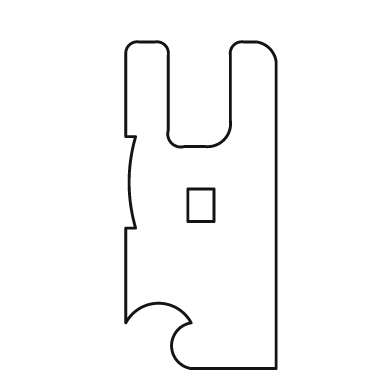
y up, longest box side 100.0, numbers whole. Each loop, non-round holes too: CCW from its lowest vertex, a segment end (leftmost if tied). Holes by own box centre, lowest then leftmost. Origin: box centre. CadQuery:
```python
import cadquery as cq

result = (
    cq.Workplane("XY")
    .moveTo(-3.0, -50.0)
    .lineTo(23.0, -50.0)
    .lineTo(23.0, 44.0)
    .threePointArc((21.0, 48.0), (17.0, 50.0))
    .lineTo(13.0, 50.0)
    .threePointArc((10.0, 49.0), (9.0, 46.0))
    .lineTo(9.0, 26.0)
    .threePointArc((7.0, 20.0), (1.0, 18.0))
    .lineTo(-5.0, 18.0)
    .threePointArc((-9.0, 19.0), (-10.0, 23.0))
    .lineTo(-10.0, 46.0)
    .threePointArc((-11.0, 49.0), (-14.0, 50.0))
    .lineTo(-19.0, 50.0)
    .threePointArc((-22.0, 49.0), (-23.0, 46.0))
    .lineTo(-23.0, 21.0)
    .lineTo(-20.0, 21.0)
    .threePointArc((-22.0, 7.0), (-20.0, -7.0))
    .lineTo(-23.0, -7.0)
    .lineTo(-23.0, -36.0)
    .threePointArc((-13.0, -30.0), (-3.0, -36.0))
    .threePointArc((-9.0, -43.0), (-3.0, -50.0))
    .close()
    .moveTo(-4.0, -5.0)
    .lineTo(4.0, -5.0)
    .lineTo(4.0, 5.0)
    .lineTo(-4.0, 5.0)
    .close()
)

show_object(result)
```